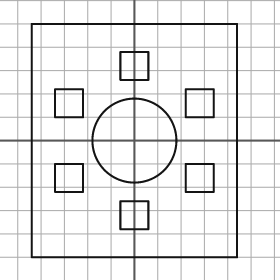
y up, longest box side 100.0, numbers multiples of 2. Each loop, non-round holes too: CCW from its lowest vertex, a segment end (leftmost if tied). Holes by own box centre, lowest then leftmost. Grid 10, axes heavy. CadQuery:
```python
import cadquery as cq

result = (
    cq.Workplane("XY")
    .moveTo(-44.0, -50.0)
    .lineTo(44.0, -50.0)
    .lineTo(44.0, 50.0)
    .lineTo(-44.0, 50.0)
    .close()
    .moveTo(-6.0, -38.0)
    .lineTo(6.0, -38.0)
    .lineTo(6.0, -26.0)
    .lineTo(-6.0, -26.0)
    .close()
    .moveTo(-34.0, -22.0)
    .lineTo(-22.0, -22.0)
    .lineTo(-22.0, -10.0)
    .lineTo(-34.0, -10.0)
    .close()
    .moveTo(22.0, -22.0)
    .lineTo(34.0, -22.0)
    .lineTo(34.0, -10.0)
    .lineTo(22.0, -10.0)
    .close()
    .moveTo(0.0, 0.0)
    .circle(18.0)
    .moveTo(-34.0, 10.0)
    .lineTo(-22.0, 10.0)
    .lineTo(-22.0, 22.0)
    .lineTo(-34.0, 22.0)
    .close()
    .moveTo(22.0, 10.0)
    .lineTo(34.0, 10.0)
    .lineTo(34.0, 22.0)
    .lineTo(22.0, 22.0)
    .close()
    .moveTo(-6.0, 26.0)
    .lineTo(6.0, 26.0)
    .lineTo(6.0, 38.0)
    .lineTo(-6.0, 38.0)
    .close()
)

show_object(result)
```